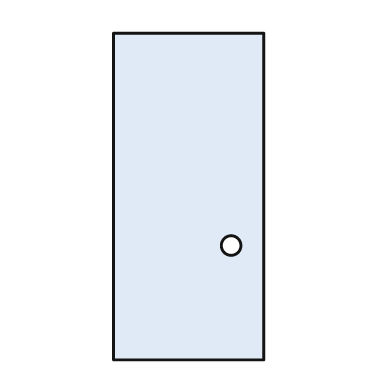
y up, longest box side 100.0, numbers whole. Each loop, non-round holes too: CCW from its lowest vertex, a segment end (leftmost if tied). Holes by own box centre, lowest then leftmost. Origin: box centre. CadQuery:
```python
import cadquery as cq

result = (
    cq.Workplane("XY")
    .moveTo(-23.0, -50.0)
    .lineTo(23.0, -50.0)
    .lineTo(23.0, 50.0)
    .lineTo(-23.0, 50.0)
    .close()
    .moveTo(13.0, -15.0)
    .circle(3.0)
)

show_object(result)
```